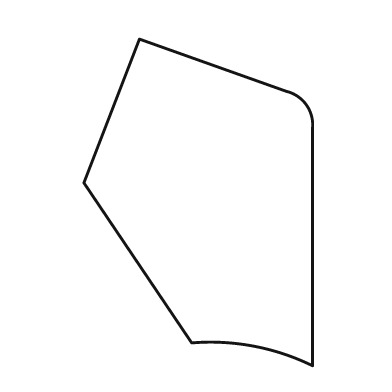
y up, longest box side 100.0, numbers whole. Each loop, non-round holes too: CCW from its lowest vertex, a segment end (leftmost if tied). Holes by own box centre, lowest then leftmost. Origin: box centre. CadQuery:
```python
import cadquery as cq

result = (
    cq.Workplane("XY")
    .moveTo(35.0, -50.0)
    .lineTo(35.0, 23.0)
    .threePointArc((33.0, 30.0), (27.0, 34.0))
    .lineTo(-18.0, 50.0)
    .lineTo(-35.0, 6.0)
    .lineTo(-2.0, -43.0)
    .threePointArc((17.0, -44.0), (35.0, -50.0))
    .close()
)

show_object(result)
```